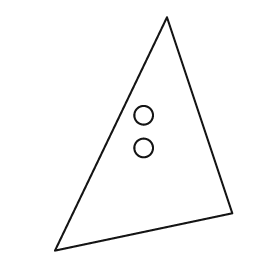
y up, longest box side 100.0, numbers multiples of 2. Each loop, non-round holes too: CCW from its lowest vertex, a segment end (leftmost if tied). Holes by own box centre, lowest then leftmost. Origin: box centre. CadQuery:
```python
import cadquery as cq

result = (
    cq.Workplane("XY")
    .moveTo(-38.0, -50.0)
    .lineTo(38.0, -34.0)
    .lineTo(10.0, 50.0)
    .close()
    .moveTo(0.0, -6.0)
    .circle(4.0)
    .moveTo(0.0, 8.0)
    .circle(4.0)
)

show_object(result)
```